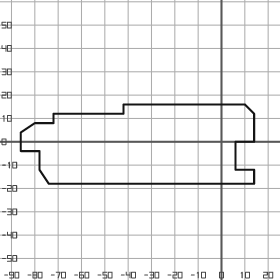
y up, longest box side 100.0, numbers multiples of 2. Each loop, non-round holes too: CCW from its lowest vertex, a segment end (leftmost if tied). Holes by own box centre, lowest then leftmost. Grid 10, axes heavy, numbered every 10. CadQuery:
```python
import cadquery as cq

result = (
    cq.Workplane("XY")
    .moveTo(-74.0, -18.0)
    .lineTo(14.0, -18.0)
    .lineTo(14.0, -12.0)
    .lineTo(6.0, -12.0)
    .lineTo(6.0, 0.0)
    .lineTo(14.0, 0.0)
    .lineTo(14.0, 12.0)
    .lineTo(10.0, 16.0)
    .lineTo(-42.0, 16.0)
    .lineTo(-42.0, 12.0)
    .lineTo(-72.0, 12.0)
    .lineTo(-72.0, 8.0)
    .lineTo(-80.0, 8.0)
    .lineTo(-86.0, 4.0)
    .lineTo(-86.0, -4.0)
    .lineTo(-78.0, -4.0)
    .lineTo(-78.0, -12.0)
    .close()
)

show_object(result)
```